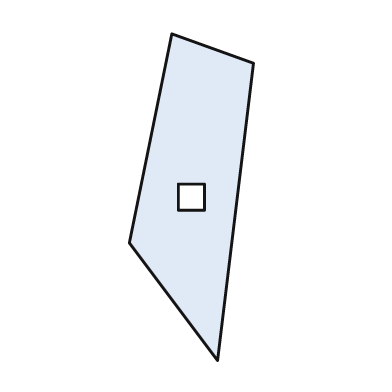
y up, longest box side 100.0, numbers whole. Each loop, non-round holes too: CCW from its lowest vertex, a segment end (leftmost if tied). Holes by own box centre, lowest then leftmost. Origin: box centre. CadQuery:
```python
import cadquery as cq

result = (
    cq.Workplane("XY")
    .moveTo(8.0, -50.0)
    .lineTo(19.0, 41.0)
    .lineTo(-6.0, 50.0)
    .lineTo(-19.0, -14.0)
    .close()
    .moveTo(-4.0, -4.0)
    .lineTo(4.0, -4.0)
    .lineTo(4.0, 4.0)
    .lineTo(-4.0, 4.0)
    .close()
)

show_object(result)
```